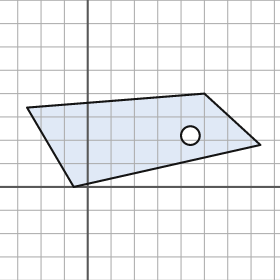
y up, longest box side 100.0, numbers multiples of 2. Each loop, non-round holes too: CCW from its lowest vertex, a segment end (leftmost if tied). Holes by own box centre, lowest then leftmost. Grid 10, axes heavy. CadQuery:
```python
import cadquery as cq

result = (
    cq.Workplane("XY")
    .moveTo(-6.0, 0.0)
    .lineTo(74.0, 18.0)
    .lineTo(50.0, 40.0)
    .lineTo(-26.0, 34.0)
    .close()
    .moveTo(44.0, 22.0)
    .circle(4.0)
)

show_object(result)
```